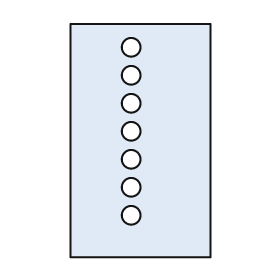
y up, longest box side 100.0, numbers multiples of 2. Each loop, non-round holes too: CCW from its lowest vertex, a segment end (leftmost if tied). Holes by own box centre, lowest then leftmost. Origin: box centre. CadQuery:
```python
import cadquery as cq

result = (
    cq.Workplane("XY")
    .moveTo(-30.0, -50.0)
    .lineTo(30.0, -50.0)
    .lineTo(30.0, 50.0)
    .lineTo(-30.0, 50.0)
    .close()
    .moveTo(-4.0, -32.0)
    .circle(4.0)
    .moveTo(-4.0, -20.0)
    .circle(4.0)
    .moveTo(-4.0, -8.0)
    .circle(4.0)
    .moveTo(-4.0, 4.0)
    .circle(4.0)
    .moveTo(-4.0, 16.0)
    .circle(4.0)
    .moveTo(-4.0, 28.0)
    .circle(4.0)
    .moveTo(-4.0, 40.0)
    .circle(4.0)
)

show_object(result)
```